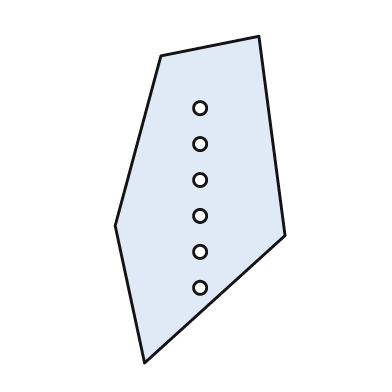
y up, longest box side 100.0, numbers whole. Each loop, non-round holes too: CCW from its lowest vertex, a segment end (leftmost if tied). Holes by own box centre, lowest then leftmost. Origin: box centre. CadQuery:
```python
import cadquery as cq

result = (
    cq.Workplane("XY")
    .moveTo(-17.0, -50.0)
    .lineTo(26.0, -11.0)
    .lineTo(18.0, 50.0)
    .lineTo(-12.0, 44.0)
    .lineTo(-26.0, -8.0)
    .close()
    .moveTo(0.0, -27.0)
    .circle(2.0)
    .moveTo(0.0, -16.0)
    .circle(2.0)
    .moveTo(0.0, -5.0)
    .circle(2.0)
    .moveTo(0.0, 6.0)
    .circle(2.0)
    .moveTo(0.0, 17.0)
    .circle(2.0)
    .moveTo(0.0, 28.0)
    .circle(2.0)
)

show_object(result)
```